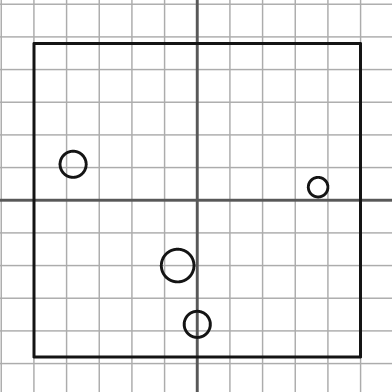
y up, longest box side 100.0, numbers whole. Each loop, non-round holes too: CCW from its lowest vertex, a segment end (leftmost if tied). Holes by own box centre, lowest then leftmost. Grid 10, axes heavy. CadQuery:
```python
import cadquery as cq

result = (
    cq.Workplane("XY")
    .moveTo(-50.0, -48.0)
    .lineTo(50.0, -48.0)
    .lineTo(50.0, 48.0)
    .lineTo(-50.0, 48.0)
    .close()
    .moveTo(0.0, -38.0)
    .circle(4.0)
    .moveTo(-6.0, -20.0)
    .circle(5.0)
    .moveTo(37.0, 4.0)
    .circle(3.0)
    .moveTo(-38.0, 11.0)
    .circle(4.0)
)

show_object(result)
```